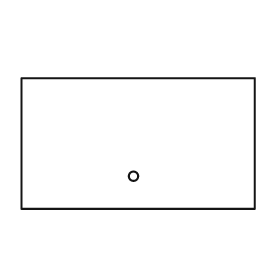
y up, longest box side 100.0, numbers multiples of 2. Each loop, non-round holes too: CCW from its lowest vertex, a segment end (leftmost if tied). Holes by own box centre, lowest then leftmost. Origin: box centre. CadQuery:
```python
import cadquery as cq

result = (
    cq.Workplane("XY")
    .moveTo(-50.0, -28.0)
    .lineTo(50.0, -28.0)
    .lineTo(50.0, 28.0)
    .lineTo(-50.0, 28.0)
    .close()
    .moveTo(-2.0, -14.0)
    .circle(2.0)
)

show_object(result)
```